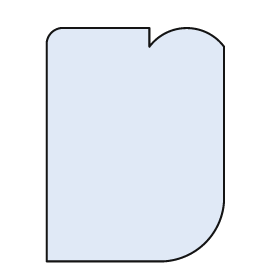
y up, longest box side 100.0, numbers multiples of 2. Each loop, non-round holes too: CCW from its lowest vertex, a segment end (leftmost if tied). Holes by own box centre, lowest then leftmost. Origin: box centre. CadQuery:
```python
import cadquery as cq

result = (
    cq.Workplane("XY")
    .moveTo(-38.0, -50.0)
    .lineTo(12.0, -50.0)
    .threePointArc((30.0, -42.0), (38.0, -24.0))
    .lineTo(38.0, 42.0)
    .threePointArc((22.0, 50.0), (6.0, 42.0))
    .lineTo(6.0, 50.0)
    .lineTo(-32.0, 50.0)
    .threePointArc((-36.0, 48.0), (-38.0, 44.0))
    .close()
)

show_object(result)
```